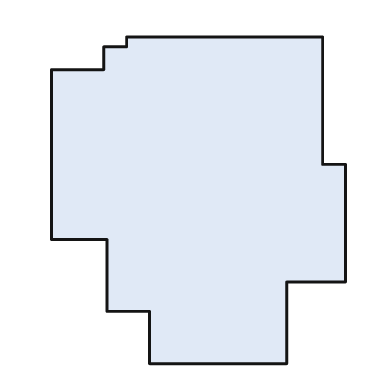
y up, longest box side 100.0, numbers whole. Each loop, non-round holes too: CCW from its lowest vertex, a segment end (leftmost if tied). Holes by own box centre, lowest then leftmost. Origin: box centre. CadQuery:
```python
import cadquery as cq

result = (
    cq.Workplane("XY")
    .moveTo(-15.0, -50.0)
    .lineTo(27.0, -50.0)
    .lineTo(27.0, -25.0)
    .lineTo(45.0, -25.0)
    .lineTo(45.0, 11.0)
    .lineTo(38.0, 11.0)
    .lineTo(38.0, 50.0)
    .lineTo(-22.0, 50.0)
    .lineTo(-22.0, 47.0)
    .lineTo(-29.0, 47.0)
    .lineTo(-29.0, 40.0)
    .lineTo(-45.0, 40.0)
    .lineTo(-45.0, -12.0)
    .lineTo(-28.0, -12.0)
    .lineTo(-28.0, -34.0)
    .lineTo(-15.0, -34.0)
    .close()
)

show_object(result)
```